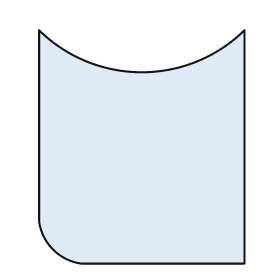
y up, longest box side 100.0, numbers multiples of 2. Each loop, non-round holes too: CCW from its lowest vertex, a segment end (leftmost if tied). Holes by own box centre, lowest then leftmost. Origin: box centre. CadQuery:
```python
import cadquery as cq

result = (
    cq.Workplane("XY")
    .moveTo(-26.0, -50.0)
    .lineTo(44.0, -50.0)
    .lineTo(44.0, 50.0)
    .threePointArc((0.0, 32.0), (-44.0, 50.0))
    .lineTo(-44.0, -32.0)
    .threePointArc((-38.0, -44.0), (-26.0, -50.0))
    .close()
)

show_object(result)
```